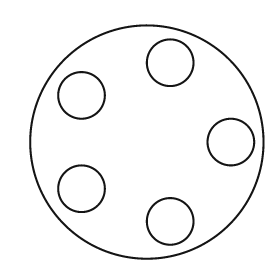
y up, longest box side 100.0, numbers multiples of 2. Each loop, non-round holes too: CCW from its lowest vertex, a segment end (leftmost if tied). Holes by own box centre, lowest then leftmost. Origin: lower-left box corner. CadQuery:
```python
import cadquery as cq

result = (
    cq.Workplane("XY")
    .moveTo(50.0, 50.0)
    .circle(50.0)
    .moveTo(60.0, 16.0)
    .circle(10.0)
    .moveTo(22.0, 30.0)
    .circle(10.0)
    .moveTo(86.0, 50.0)
    .circle(10.0)
    .moveTo(22.0, 70.0)
    .circle(10.0)
    .moveTo(60.0, 84.0)
    .circle(10.0)
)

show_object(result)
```